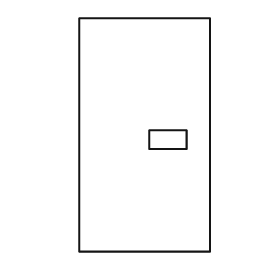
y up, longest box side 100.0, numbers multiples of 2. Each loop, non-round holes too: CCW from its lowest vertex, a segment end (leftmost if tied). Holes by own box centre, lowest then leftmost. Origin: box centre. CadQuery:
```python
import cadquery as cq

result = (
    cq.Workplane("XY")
    .moveTo(-28.0, -50.0)
    .lineTo(28.0, -50.0)
    .lineTo(28.0, 50.0)
    .lineTo(-28.0, 50.0)
    .close()
    .moveTo(2.0, -6.0)
    .lineTo(18.0, -6.0)
    .lineTo(18.0, 2.0)
    .lineTo(2.0, 2.0)
    .close()
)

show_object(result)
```